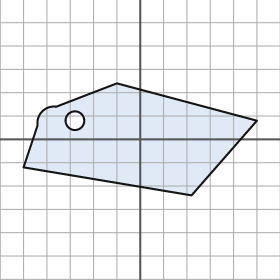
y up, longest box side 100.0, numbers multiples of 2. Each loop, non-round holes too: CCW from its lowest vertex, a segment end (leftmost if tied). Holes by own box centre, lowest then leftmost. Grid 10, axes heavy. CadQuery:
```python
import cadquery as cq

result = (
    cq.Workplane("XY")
    .moveTo(22.0, -24.0)
    .lineTo(50.0, 8.0)
    .lineTo(-10.0, 24.0)
    .lineTo(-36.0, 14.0)
    .threePointArc((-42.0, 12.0), (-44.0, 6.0))
    .lineTo(-50.0, -12.0)
    .close()
    .moveTo(-28.0, 8.0)
    .circle(4.0)
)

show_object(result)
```